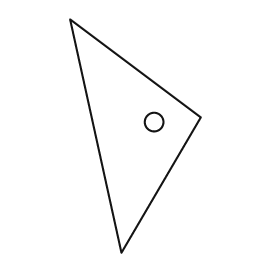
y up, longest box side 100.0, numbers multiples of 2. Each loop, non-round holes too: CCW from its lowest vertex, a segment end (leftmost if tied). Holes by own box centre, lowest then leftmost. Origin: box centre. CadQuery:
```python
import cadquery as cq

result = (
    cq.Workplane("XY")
    .moveTo(-6.0, -50.0)
    .lineTo(28.0, 8.0)
    .lineTo(-28.0, 50.0)
    .close()
    .moveTo(8.0, 6.0)
    .circle(4.0)
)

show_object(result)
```